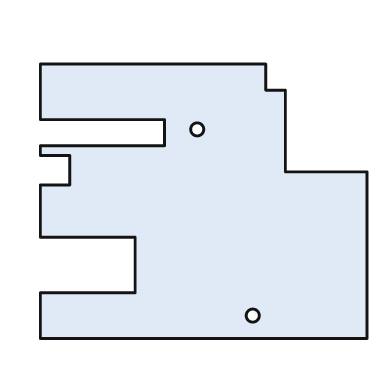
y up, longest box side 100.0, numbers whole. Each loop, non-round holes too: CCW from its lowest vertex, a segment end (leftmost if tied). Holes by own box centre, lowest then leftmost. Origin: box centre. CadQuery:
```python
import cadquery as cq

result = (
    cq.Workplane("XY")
    .moveTo(-50.0, -42.0)
    .lineTo(50.0, -42.0)
    .lineTo(50.0, 9.0)
    .lineTo(25.0, 9.0)
    .lineTo(25.0, 34.0)
    .lineTo(19.0, 34.0)
    .lineTo(19.0, 42.0)
    .lineTo(-50.0, 42.0)
    .lineTo(-50.0, 25.0)
    .lineTo(-12.0, 25.0)
    .lineTo(-12.0, 17.0)
    .lineTo(-50.0, 17.0)
    .lineTo(-50.0, 14.0)
    .lineTo(-41.0, 14.0)
    .lineTo(-41.0, 5.0)
    .lineTo(-50.0, 5.0)
    .lineTo(-50.0, -11.0)
    .lineTo(-21.0, -11.0)
    .lineTo(-21.0, -28.0)
    .lineTo(-50.0, -28.0)
    .close()
    .moveTo(15.0, -35.0)
    .circle(2.0)
    .moveTo(-2.0, 22.0)
    .circle(2.0)
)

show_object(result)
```